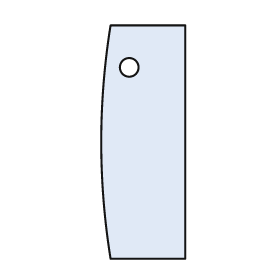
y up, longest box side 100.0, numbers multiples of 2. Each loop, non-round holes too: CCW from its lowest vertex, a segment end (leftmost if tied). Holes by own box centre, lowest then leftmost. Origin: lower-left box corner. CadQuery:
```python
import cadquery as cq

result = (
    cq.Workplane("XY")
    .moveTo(4.0, 0.0)
    .lineTo(36.0, 0.0)
    .lineTo(36.0, 100.0)
    .lineTo(4.0, 100.0)
    .threePointArc((0.0, 50.0), (4.0, 0.0))
    .close()
    .moveTo(12.0, 82.0)
    .circle(4.0)
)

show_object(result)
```